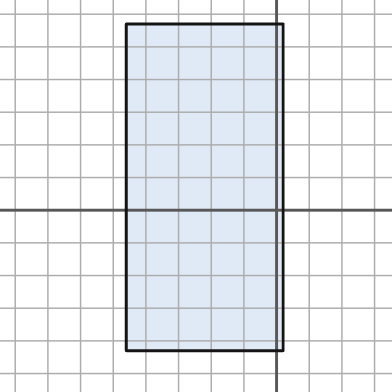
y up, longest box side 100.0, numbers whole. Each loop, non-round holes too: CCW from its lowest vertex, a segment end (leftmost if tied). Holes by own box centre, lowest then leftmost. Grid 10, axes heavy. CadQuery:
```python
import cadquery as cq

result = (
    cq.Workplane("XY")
    .moveTo(-46.0, -43.0)
    .lineTo(2.0, -43.0)
    .lineTo(2.0, 57.0)
    .lineTo(-46.0, 57.0)
    .close()
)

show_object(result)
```